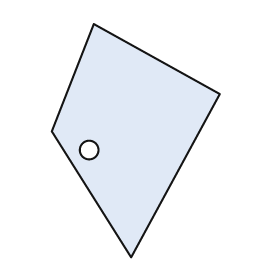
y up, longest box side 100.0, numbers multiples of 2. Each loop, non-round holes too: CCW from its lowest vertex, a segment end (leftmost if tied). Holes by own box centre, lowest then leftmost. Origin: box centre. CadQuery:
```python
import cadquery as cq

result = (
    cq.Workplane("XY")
    .moveTo(-2.0, -50.0)
    .lineTo(36.0, 20.0)
    .lineTo(-18.0, 50.0)
    .lineTo(-36.0, 4.0)
    .close()
    .moveTo(-20.0, -4.0)
    .circle(4.0)
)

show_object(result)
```